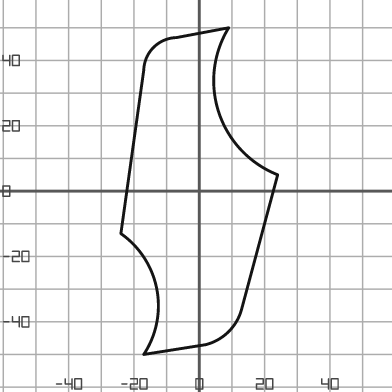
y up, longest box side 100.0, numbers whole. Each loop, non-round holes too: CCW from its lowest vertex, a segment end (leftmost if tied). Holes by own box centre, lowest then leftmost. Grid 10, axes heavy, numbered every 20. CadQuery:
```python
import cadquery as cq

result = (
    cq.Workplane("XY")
    .moveTo(-17.0, -50.0)
    .lineTo(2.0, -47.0)
    .threePointArc((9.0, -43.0), (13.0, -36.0))
    .lineTo(24.0, 5.0)
    .threePointArc((6.0, 24.0), (9.0, 50.0))
    .lineTo(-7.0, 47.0)
    .threePointArc((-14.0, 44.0), (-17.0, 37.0))
    .lineTo(-24.0, -13.0)
    .threePointArc((-13.0, -30.0), (-17.0, -50.0))
    .close()
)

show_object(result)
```